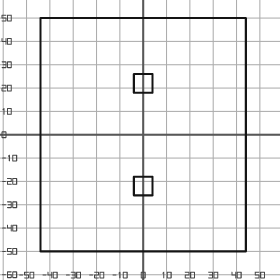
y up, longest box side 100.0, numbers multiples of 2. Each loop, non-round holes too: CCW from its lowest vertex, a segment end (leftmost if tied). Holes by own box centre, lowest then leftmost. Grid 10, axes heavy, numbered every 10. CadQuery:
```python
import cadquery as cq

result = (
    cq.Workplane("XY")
    .moveTo(-44.0, -50.0)
    .lineTo(44.0, -50.0)
    .lineTo(44.0, 50.0)
    .lineTo(-44.0, 50.0)
    .close()
    .moveTo(-4.0, -26.0)
    .lineTo(4.0, -26.0)
    .lineTo(4.0, -18.0)
    .lineTo(-4.0, -18.0)
    .close()
    .moveTo(-4.0, 18.0)
    .lineTo(4.0, 18.0)
    .lineTo(4.0, 26.0)
    .lineTo(-4.0, 26.0)
    .close()
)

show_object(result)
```